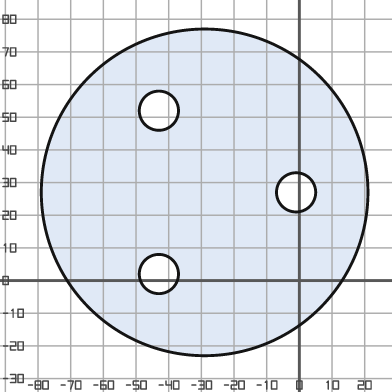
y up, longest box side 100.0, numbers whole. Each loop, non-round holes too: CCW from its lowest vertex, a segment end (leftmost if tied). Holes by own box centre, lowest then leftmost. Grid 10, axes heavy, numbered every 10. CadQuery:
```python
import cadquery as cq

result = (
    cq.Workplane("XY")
    .moveTo(-29.0, 27.0)
    .circle(50.0)
    .moveTo(-43.0, 2.0)
    .circle(6.0)
    .moveTo(-1.0, 27.0)
    .circle(6.0)
    .moveTo(-43.0, 52.0)
    .circle(6.0)
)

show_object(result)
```